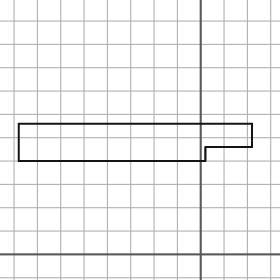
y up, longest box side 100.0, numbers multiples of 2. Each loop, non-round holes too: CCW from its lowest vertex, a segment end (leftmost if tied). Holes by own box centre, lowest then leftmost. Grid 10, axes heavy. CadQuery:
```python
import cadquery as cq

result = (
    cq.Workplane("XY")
    .moveTo(-78.0, 40.0)
    .lineTo(2.0, 40.0)
    .lineTo(2.0, 46.0)
    .lineTo(22.0, 46.0)
    .lineTo(22.0, 56.0)
    .lineTo(-78.0, 56.0)
    .close()
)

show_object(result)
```